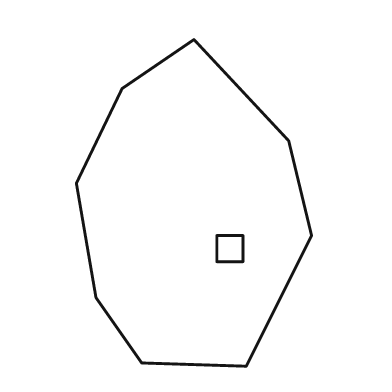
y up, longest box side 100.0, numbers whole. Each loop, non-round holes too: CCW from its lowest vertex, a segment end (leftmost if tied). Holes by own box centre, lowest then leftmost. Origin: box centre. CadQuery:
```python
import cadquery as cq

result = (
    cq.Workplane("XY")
    .moveTo(16.0, -50.0)
    .lineTo(36.0, -10.0)
    .lineTo(29.0, 19.0)
    .lineTo(0.0, 50.0)
    .lineTo(-22.0, 35.0)
    .lineTo(-36.0, 6.0)
    .lineTo(-30.0, -29.0)
    .lineTo(-16.0, -49.0)
    .close()
    .moveTo(7.0, -18.0)
    .lineTo(15.0, -18.0)
    .lineTo(15.0, -10.0)
    .lineTo(7.0, -10.0)
    .close()
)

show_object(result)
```